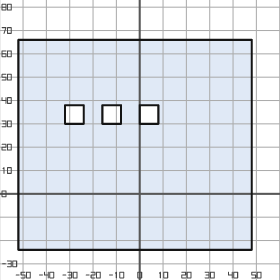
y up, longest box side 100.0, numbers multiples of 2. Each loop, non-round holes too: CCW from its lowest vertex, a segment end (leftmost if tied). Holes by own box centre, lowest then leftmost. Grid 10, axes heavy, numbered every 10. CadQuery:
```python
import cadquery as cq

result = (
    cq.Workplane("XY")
    .moveTo(-52.0, -24.0)
    .lineTo(48.0, -24.0)
    .lineTo(48.0, 66.0)
    .lineTo(-52.0, 66.0)
    .close()
    .moveTo(-32.0, 30.0)
    .lineTo(-24.0, 30.0)
    .lineTo(-24.0, 38.0)
    .lineTo(-32.0, 38.0)
    .close()
    .moveTo(-16.0, 30.0)
    .lineTo(-8.0, 30.0)
    .lineTo(-8.0, 38.0)
    .lineTo(-16.0, 38.0)
    .close()
    .moveTo(0.0, 30.0)
    .lineTo(8.0, 30.0)
    .lineTo(8.0, 38.0)
    .lineTo(0.0, 38.0)
    .close()
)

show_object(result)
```